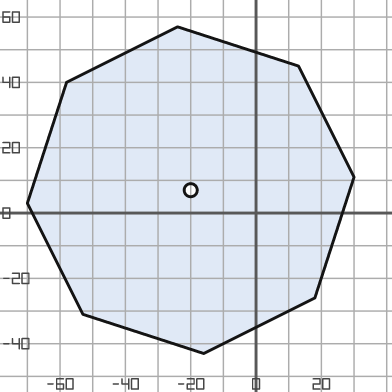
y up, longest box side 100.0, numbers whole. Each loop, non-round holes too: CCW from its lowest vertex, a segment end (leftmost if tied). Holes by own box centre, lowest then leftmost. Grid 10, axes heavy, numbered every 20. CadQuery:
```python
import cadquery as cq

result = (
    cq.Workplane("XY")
    .moveTo(-16.0, -43.0)
    .lineTo(18.0, -26.0)
    .lineTo(30.0, 11.0)
    .lineTo(13.0, 45.0)
    .lineTo(-24.0, 57.0)
    .lineTo(-58.0, 40.0)
    .lineTo(-70.0, 3.0)
    .lineTo(-53.0, -31.0)
    .close()
    .moveTo(-20.0, 7.0)
    .circle(2.0)
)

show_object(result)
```